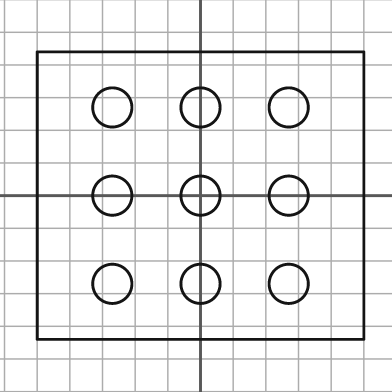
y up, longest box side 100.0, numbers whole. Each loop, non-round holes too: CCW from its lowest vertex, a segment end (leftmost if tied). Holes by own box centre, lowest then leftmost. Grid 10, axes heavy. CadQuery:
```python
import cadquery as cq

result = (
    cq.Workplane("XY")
    .moveTo(-50.0, -44.0)
    .lineTo(50.0, -44.0)
    .lineTo(50.0, 44.0)
    .lineTo(-50.0, 44.0)
    .close()
    .moveTo(-27.0, -27.0)
    .circle(6.0)
    .moveTo(0.0, -27.0)
    .circle(6.0)
    .moveTo(27.0, -27.0)
    .circle(6.0)
    .moveTo(-27.0, 0.0)
    .circle(6.0)
    .moveTo(0.0, 0.0)
    .circle(6.0)
    .moveTo(27.0, 0.0)
    .circle(6.0)
    .moveTo(-27.0, 27.0)
    .circle(6.0)
    .moveTo(0.0, 27.0)
    .circle(6.0)
    .moveTo(27.0, 27.0)
    .circle(6.0)
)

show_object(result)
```